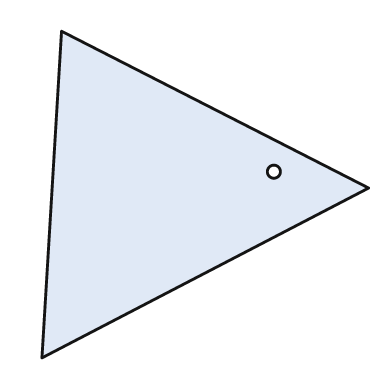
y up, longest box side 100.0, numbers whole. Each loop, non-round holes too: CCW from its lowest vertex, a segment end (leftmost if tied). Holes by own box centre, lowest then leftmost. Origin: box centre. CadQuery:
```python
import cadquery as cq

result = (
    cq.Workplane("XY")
    .moveTo(-50.0, -50.0)
    .lineTo(50.0, 2.0)
    .lineTo(-44.0, 50.0)
    .close()
    .moveTo(21.0, 7.0)
    .circle(2.0)
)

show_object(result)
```